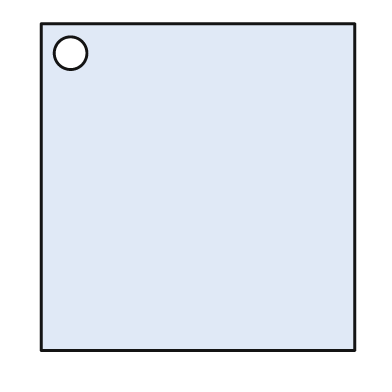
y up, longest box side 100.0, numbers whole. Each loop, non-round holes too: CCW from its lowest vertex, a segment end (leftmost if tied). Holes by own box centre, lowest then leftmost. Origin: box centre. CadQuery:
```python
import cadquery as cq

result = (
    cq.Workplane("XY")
    .moveTo(-48.0, -50.0)
    .lineTo(48.0, -50.0)
    .lineTo(48.0, 50.0)
    .lineTo(-48.0, 50.0)
    .close()
    .moveTo(-39.0, 41.0)
    .circle(5.0)
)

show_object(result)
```